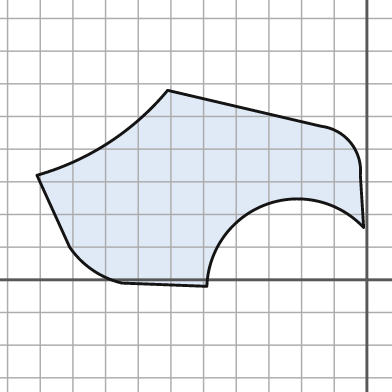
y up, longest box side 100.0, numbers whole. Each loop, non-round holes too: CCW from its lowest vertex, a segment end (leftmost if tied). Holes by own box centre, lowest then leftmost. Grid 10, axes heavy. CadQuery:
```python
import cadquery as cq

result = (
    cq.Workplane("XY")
    .moveTo(-49.0, -2.0)
    .threePointArc((-31.0, 23.0), (-1.0, 16.0))
    .lineTo(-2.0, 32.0)
    .threePointArc((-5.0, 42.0), (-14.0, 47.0))
    .lineTo(-61.0, 58.0)
    .threePointArc((-79.0, 42.0), (-101.0, 32.0))
    .lineTo(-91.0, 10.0)
    .threePointArc((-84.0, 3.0), (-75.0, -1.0))
    .close()
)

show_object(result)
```